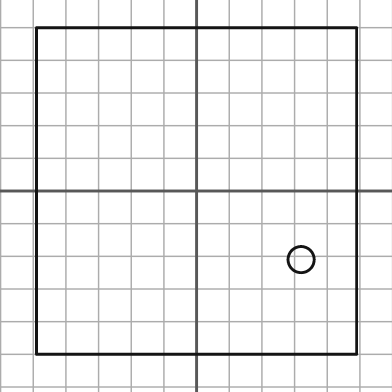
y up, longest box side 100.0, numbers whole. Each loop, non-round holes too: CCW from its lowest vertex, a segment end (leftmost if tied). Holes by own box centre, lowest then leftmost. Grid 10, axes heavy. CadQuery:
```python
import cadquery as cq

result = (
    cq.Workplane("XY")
    .moveTo(-49.0, -50.0)
    .lineTo(49.0, -50.0)
    .lineTo(49.0, 50.0)
    .lineTo(-49.0, 50.0)
    .close()
    .moveTo(32.0, -21.0)
    .circle(4.0)
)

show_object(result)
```